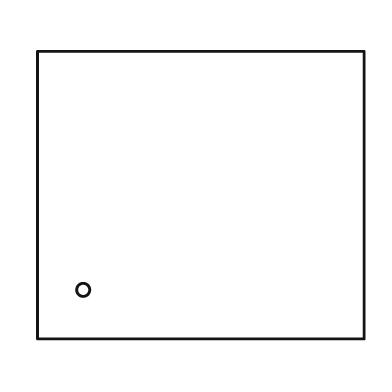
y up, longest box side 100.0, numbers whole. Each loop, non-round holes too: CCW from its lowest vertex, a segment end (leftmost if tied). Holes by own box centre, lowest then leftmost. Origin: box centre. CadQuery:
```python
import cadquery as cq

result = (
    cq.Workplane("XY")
    .moveTo(-50.0, -44.0)
    .lineTo(50.0, -44.0)
    .lineTo(50.0, 44.0)
    .lineTo(-50.0, 44.0)
    .close()
    .moveTo(-36.0, -29.0)
    .circle(2.0)
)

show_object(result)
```